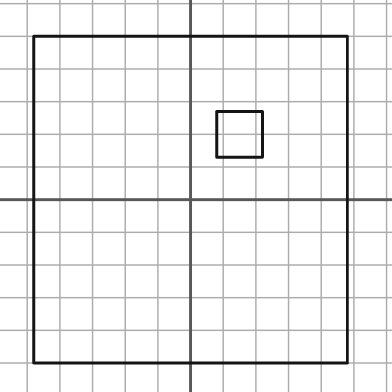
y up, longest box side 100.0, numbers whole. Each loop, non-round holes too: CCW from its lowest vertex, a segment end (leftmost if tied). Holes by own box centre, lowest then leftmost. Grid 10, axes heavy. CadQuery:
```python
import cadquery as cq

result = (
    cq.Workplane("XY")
    .moveTo(-48.0, -50.0)
    .lineTo(48.0, -50.0)
    .lineTo(48.0, 50.0)
    .lineTo(-48.0, 50.0)
    .close()
    .moveTo(8.0, 13.0)
    .lineTo(22.0, 13.0)
    .lineTo(22.0, 27.0)
    .lineTo(8.0, 27.0)
    .close()
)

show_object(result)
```